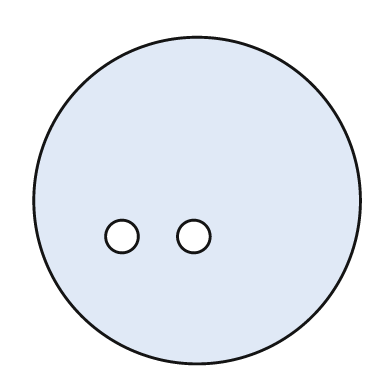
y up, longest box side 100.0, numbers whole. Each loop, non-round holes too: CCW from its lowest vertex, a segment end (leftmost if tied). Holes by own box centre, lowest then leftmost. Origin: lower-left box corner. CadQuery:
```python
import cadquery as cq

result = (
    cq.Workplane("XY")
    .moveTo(50.0, 50.0)
    .circle(50.0)
    .moveTo(27.0, 39.0)
    .circle(5.0)
    .moveTo(49.0, 39.0)
    .circle(5.0)
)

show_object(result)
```